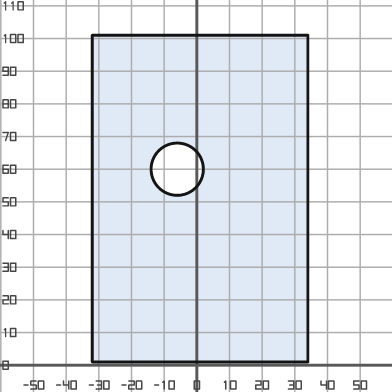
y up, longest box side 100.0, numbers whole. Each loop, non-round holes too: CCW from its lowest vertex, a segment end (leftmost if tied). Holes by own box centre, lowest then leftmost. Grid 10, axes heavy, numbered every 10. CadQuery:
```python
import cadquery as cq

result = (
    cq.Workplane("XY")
    .moveTo(-32.0, 1.0)
    .lineTo(34.0, 1.0)
    .lineTo(34.0, 101.0)
    .lineTo(-32.0, 101.0)
    .close()
    .moveTo(-6.0, 60.0)
    .circle(8.0)
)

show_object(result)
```